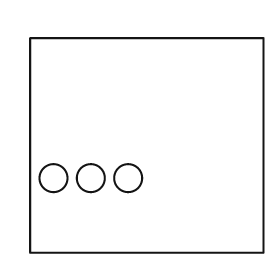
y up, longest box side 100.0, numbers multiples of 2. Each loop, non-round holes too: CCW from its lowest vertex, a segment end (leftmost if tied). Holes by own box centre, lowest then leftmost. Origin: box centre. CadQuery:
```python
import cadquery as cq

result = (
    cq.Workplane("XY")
    .moveTo(-50.0, -46.0)
    .lineTo(50.0, -46.0)
    .lineTo(50.0, 46.0)
    .lineTo(-50.0, 46.0)
    .close()
    .moveTo(-40.0, -14.0)
    .circle(6.0)
    .moveTo(-24.0, -14.0)
    .circle(6.0)
    .moveTo(-8.0, -14.0)
    .circle(6.0)
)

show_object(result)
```